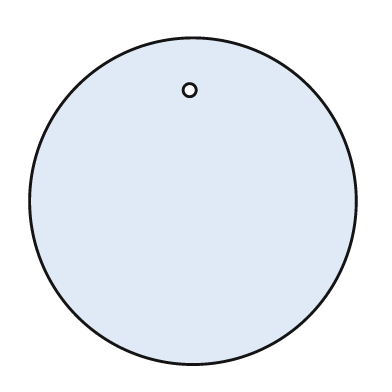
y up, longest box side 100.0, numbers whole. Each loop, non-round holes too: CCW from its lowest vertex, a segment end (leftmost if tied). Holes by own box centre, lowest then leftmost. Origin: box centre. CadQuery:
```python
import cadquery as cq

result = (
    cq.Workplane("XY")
    .moveTo(0.0, 0.0)
    .circle(50.0)
    .moveTo(-1.0, 34.0)
    .circle(2.0)
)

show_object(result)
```